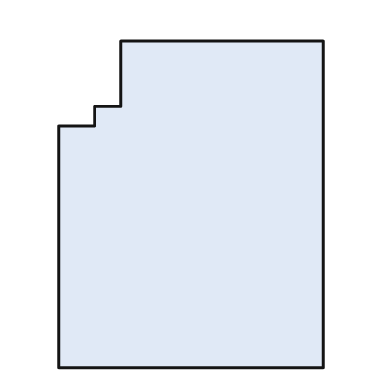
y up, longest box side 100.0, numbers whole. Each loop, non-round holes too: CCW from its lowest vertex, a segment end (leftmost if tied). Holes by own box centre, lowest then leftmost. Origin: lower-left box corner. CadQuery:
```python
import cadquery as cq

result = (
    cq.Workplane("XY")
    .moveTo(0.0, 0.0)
    .lineTo(81.0, 0.0)
    .lineTo(81.0, 100.0)
    .lineTo(19.0, 100.0)
    .lineTo(19.0, 80.0)
    .lineTo(11.0, 80.0)
    .lineTo(11.0, 74.0)
    .lineTo(0.0, 74.0)
    .close()
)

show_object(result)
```